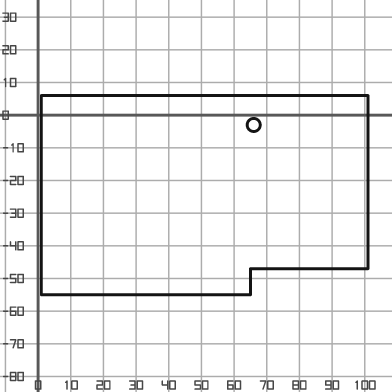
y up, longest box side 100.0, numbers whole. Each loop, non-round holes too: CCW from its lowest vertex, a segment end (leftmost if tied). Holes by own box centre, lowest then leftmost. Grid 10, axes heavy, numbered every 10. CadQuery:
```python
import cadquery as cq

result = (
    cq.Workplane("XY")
    .moveTo(1.0, -55.0)
    .lineTo(65.0, -55.0)
    .lineTo(65.0, -47.0)
    .lineTo(101.0, -47.0)
    .lineTo(101.0, 6.0)
    .lineTo(1.0, 6.0)
    .close()
    .moveTo(66.0, -3.0)
    .circle(2.0)
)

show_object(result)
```